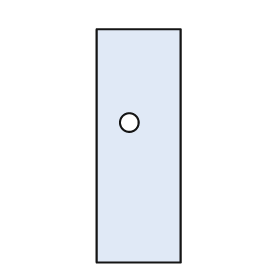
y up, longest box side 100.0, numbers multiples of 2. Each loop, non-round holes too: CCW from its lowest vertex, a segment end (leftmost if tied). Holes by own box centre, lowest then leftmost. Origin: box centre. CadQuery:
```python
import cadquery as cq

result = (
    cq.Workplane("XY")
    .moveTo(-18.0, -50.0)
    .lineTo(18.0, -50.0)
    .lineTo(18.0, 50.0)
    .lineTo(-18.0, 50.0)
    .close()
    .moveTo(-4.0, 10.0)
    .circle(4.0)
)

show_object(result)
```